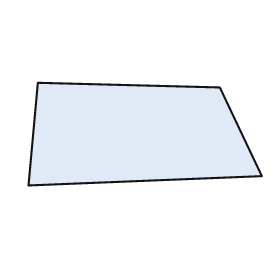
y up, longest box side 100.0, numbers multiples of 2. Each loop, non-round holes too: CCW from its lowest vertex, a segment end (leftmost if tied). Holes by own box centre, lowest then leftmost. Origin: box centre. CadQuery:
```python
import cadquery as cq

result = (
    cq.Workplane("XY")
    .moveTo(-50.0, -22.0)
    .lineTo(50.0, -18.0)
    .lineTo(32.0, 20.0)
    .lineTo(-46.0, 22.0)
    .close()
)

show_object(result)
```